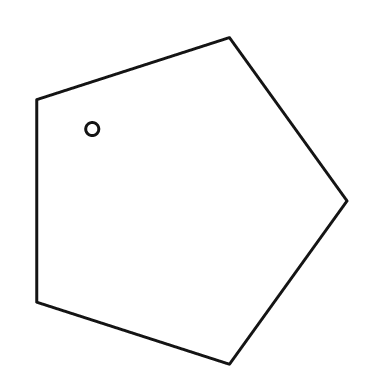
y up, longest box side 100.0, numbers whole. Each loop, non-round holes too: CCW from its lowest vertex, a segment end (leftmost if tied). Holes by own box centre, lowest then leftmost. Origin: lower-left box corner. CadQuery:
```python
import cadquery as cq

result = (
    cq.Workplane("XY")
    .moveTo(59.0, 0.0)
    .lineTo(95.0, 50.0)
    .lineTo(59.0, 100.0)
    .lineTo(0.0, 81.0)
    .lineTo(0.0, 19.0)
    .close()
    .moveTo(17.0, 72.0)
    .circle(2.0)
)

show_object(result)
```